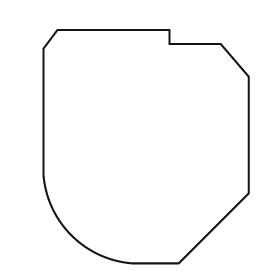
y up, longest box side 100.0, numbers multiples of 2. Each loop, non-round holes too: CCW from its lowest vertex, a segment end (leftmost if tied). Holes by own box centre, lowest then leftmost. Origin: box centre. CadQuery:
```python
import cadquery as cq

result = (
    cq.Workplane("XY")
    .moveTo(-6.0, -50.0)
    .lineTo(14.0, -50.0)
    .lineTo(44.0, -20.0)
    .lineTo(44.0, 30.0)
    .lineTo(32.0, 44.0)
    .lineTo(10.0, 44.0)
    .lineTo(10.0, 50.0)
    .lineTo(-38.0, 50.0)
    .lineTo(-44.0, 42.0)
    .lineTo(-44.0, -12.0)
    .threePointArc((-32.0, -38.0), (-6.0, -50.0))
    .close()
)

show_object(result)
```